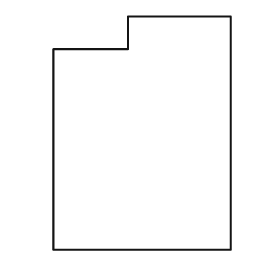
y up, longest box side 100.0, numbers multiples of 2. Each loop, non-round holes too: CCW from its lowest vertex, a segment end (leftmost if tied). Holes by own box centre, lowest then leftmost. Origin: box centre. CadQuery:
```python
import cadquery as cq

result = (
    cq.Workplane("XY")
    .moveTo(-38.0, -50.0)
    .lineTo(38.0, -50.0)
    .lineTo(38.0, 50.0)
    .lineTo(-6.0, 50.0)
    .lineTo(-6.0, 36.0)
    .lineTo(-38.0, 36.0)
    .close()
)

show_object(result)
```